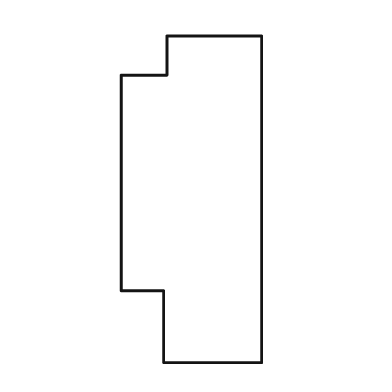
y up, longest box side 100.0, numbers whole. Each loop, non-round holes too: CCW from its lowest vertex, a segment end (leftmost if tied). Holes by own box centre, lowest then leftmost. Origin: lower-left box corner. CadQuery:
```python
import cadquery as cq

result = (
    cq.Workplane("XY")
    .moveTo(13.0, 0.0)
    .lineTo(43.0, 0.0)
    .lineTo(43.0, 100.0)
    .lineTo(14.0, 100.0)
    .lineTo(14.0, 88.0)
    .lineTo(0.0, 88.0)
    .lineTo(0.0, 22.0)
    .lineTo(13.0, 22.0)
    .close()
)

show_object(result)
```